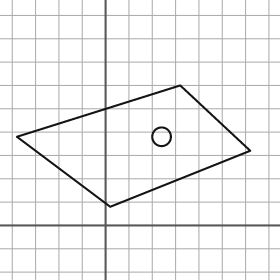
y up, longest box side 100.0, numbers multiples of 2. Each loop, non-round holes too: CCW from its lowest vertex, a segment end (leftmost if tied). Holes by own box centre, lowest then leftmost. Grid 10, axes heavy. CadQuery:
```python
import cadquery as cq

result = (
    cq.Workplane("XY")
    .moveTo(2.0, 8.0)
    .lineTo(62.0, 32.0)
    .lineTo(32.0, 60.0)
    .lineTo(-38.0, 38.0)
    .close()
    .moveTo(24.0, 38.0)
    .circle(4.0)
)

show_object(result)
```